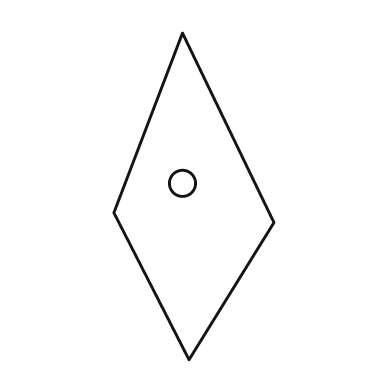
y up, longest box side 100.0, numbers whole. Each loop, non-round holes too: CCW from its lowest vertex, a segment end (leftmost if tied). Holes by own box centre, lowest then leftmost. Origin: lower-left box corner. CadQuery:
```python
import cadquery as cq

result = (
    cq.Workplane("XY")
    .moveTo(23.0, 0.0)
    .lineTo(49.0, 42.0)
    .lineTo(21.0, 100.0)
    .lineTo(0.0, 45.0)
    .close()
    .moveTo(21.0, 54.0)
    .circle(4.0)
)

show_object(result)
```